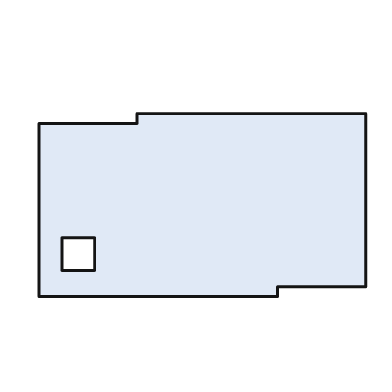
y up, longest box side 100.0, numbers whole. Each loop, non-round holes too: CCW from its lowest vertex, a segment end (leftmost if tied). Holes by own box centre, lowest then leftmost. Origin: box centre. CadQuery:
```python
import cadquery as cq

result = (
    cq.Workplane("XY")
    .moveTo(-50.0, -28.0)
    .lineTo(23.0, -28.0)
    .lineTo(23.0, -25.0)
    .lineTo(50.0, -25.0)
    .lineTo(50.0, 28.0)
    .lineTo(-20.0, 28.0)
    .lineTo(-20.0, 25.0)
    .lineTo(-50.0, 25.0)
    .close()
    .moveTo(-43.0, -20.0)
    .lineTo(-33.0, -20.0)
    .lineTo(-33.0, -10.0)
    .lineTo(-43.0, -10.0)
    .close()
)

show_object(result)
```